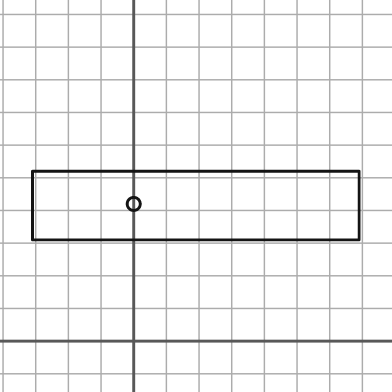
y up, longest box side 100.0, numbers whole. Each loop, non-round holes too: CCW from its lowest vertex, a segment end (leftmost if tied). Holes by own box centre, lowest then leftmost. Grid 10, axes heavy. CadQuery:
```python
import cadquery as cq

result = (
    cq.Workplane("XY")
    .moveTo(-31.0, 31.0)
    .lineTo(69.0, 31.0)
    .lineTo(69.0, 52.0)
    .lineTo(-31.0, 52.0)
    .close()
    .moveTo(0.0, 42.0)
    .circle(2.0)
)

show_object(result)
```